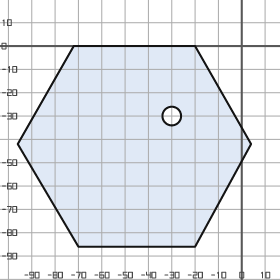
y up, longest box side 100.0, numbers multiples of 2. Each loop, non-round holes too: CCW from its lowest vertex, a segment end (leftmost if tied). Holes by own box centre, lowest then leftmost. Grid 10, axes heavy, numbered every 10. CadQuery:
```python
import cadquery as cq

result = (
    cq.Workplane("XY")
    .moveTo(-70.0, -86.0)
    .lineTo(-20.0, -86.0)
    .lineTo(4.0, -42.0)
    .lineTo(-20.0, 0.0)
    .lineTo(-72.0, 0.0)
    .lineTo(-96.0, -42.0)
    .close()
    .moveTo(-30.0, -30.0)
    .circle(4.0)
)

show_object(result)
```